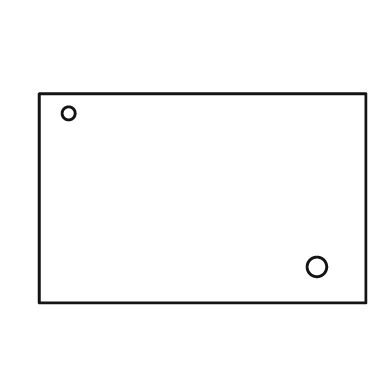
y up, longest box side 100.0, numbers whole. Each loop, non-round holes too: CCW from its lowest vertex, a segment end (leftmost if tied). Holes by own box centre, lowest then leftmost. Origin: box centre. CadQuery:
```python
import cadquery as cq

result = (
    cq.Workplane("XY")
    .moveTo(-50.0, -32.0)
    .lineTo(50.0, -32.0)
    .lineTo(50.0, 32.0)
    .lineTo(-50.0, 32.0)
    .close()
    .moveTo(35.0, -21.0)
    .circle(3.0)
    .moveTo(-41.0, 26.0)
    .circle(2.0)
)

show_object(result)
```